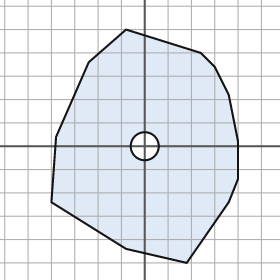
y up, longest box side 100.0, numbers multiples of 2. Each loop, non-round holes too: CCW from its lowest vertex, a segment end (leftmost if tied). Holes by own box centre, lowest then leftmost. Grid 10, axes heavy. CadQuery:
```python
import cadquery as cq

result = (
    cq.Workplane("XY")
    .moveTo(18.0, -50.0)
    .lineTo(36.0, -24.0)
    .lineTo(40.0, -14.0)
    .lineTo(40.0, 2.0)
    .lineTo(36.0, 22.0)
    .lineTo(30.0, 34.0)
    .lineTo(24.0, 40.0)
    .lineTo(-8.0, 50.0)
    .lineTo(-24.0, 36.0)
    .lineTo(-38.0, 4.0)
    .lineTo(-40.0, -24.0)
    .lineTo(-8.0, -44.0)
    .close()
    .moveTo(0.0, 0.0)
    .circle(6.0)
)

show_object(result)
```